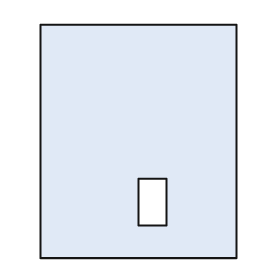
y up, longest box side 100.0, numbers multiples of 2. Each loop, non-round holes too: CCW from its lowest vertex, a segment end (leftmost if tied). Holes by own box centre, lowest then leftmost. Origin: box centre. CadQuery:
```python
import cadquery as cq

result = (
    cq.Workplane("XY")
    .moveTo(-42.0, -50.0)
    .lineTo(42.0, -50.0)
    .lineTo(42.0, 50.0)
    .lineTo(-42.0, 50.0)
    .close()
    .moveTo(0.0, -36.0)
    .lineTo(12.0, -36.0)
    .lineTo(12.0, -16.0)
    .lineTo(0.0, -16.0)
    .close()
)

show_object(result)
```